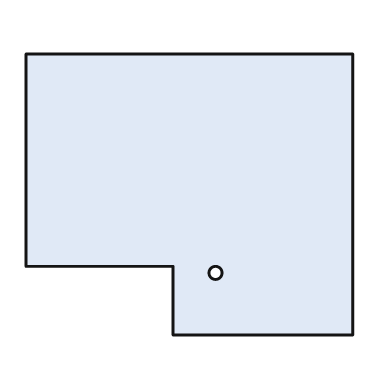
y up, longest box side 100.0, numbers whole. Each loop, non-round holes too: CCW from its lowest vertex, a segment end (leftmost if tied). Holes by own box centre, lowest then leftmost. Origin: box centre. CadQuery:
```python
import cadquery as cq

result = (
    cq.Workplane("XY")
    .moveTo(-5.0, -43.0)
    .lineTo(50.0, -43.0)
    .lineTo(50.0, 43.0)
    .lineTo(-50.0, 43.0)
    .lineTo(-50.0, -22.0)
    .lineTo(-5.0, -22.0)
    .close()
    .moveTo(8.0, -24.0)
    .circle(2.0)
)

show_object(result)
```